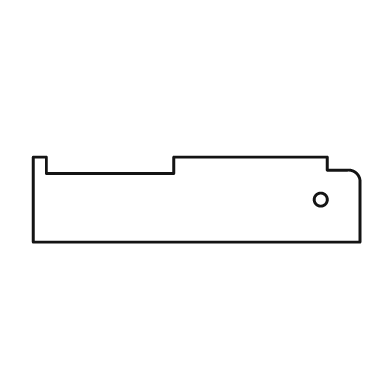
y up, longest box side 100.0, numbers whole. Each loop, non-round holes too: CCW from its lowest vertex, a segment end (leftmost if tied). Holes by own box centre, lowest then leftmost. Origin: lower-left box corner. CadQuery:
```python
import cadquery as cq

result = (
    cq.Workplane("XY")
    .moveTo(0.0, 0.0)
    .lineTo(100.0, 0.0)
    .lineTo(100.0, 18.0)
    .threePointArc((99.0, 21.0), (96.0, 22.0))
    .lineTo(90.0, 22.0)
    .lineTo(90.0, 26.0)
    .lineTo(43.0, 26.0)
    .lineTo(43.0, 21.0)
    .lineTo(4.0, 21.0)
    .lineTo(4.0, 26.0)
    .lineTo(0.0, 26.0)
    .close()
    .moveTo(88.0, 13.0)
    .circle(2.0)
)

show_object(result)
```